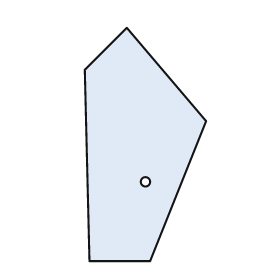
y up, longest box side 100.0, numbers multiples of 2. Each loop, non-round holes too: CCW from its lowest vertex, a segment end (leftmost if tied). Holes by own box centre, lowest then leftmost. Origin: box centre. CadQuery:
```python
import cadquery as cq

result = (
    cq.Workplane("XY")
    .moveTo(-24.0, -50.0)
    .lineTo(2.0, -50.0)
    .lineTo(26.0, 10.0)
    .lineTo(-8.0, 50.0)
    .lineTo(-26.0, 32.0)
    .close()
    .moveTo(0.0, -16.0)
    .circle(2.0)
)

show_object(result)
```